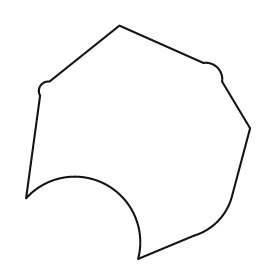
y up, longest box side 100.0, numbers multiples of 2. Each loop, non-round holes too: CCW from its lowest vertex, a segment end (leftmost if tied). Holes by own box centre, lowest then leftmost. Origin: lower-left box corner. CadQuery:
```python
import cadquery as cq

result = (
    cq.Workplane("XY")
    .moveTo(48.0, 0.0)
    .lineTo(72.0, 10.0)
    .threePointArc((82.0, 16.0), (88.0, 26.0))
    .lineTo(96.0, 56.0)
    .lineTo(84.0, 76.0)
    .threePointArc((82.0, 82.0), (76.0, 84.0))
    .lineTo(40.0, 100.0)
    .lineTo(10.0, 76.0)
    .threePointArc((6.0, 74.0), (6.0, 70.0))
    .lineTo(0.0, 26.0)
    .threePointArc((34.0, 32.0), (48.0, 0.0))
    .close()
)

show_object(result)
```